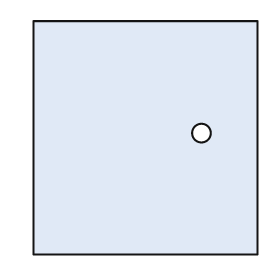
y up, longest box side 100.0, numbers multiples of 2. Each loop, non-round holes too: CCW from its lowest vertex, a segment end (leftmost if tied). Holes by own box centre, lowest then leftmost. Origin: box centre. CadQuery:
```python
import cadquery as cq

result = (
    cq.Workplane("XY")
    .moveTo(-48.0, -50.0)
    .lineTo(48.0, -50.0)
    .lineTo(48.0, 50.0)
    .lineTo(-48.0, 50.0)
    .close()
    .moveTo(24.0, 2.0)
    .circle(4.0)
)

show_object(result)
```